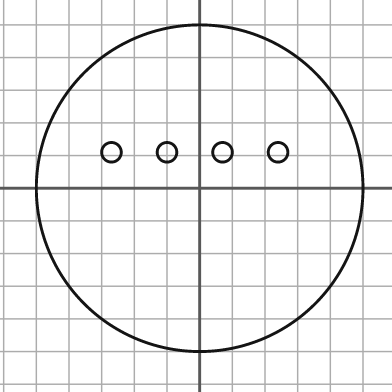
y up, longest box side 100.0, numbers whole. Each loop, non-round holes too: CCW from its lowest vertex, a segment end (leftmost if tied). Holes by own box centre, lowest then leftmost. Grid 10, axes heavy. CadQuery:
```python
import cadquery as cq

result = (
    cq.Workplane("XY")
    .moveTo(0.0, 0.0)
    .circle(50.0)
    .moveTo(-27.0, 11.0)
    .circle(3.0)
    .moveTo(-10.0, 11.0)
    .circle(3.0)
    .moveTo(7.0, 11.0)
    .circle(3.0)
    .moveTo(24.0, 11.0)
    .circle(3.0)
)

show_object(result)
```